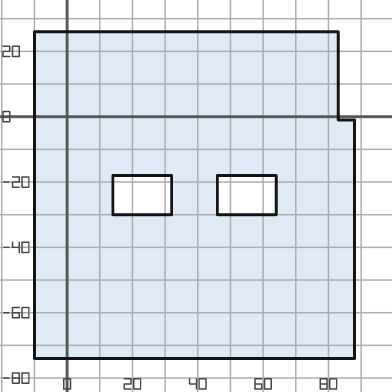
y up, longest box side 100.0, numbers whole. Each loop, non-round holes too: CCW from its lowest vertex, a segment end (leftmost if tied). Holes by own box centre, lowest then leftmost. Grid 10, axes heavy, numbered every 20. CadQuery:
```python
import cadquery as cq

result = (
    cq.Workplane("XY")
    .moveTo(-10.0, -74.0)
    .lineTo(88.0, -74.0)
    .lineTo(88.0, -1.0)
    .lineTo(83.0, -1.0)
    .lineTo(83.0, 26.0)
    .lineTo(-10.0, 26.0)
    .close()
    .moveTo(14.0, -30.0)
    .lineTo(32.0, -30.0)
    .lineTo(32.0, -18.0)
    .lineTo(14.0, -18.0)
    .close()
    .moveTo(46.0, -30.0)
    .lineTo(64.0, -30.0)
    .lineTo(64.0, -18.0)
    .lineTo(46.0, -18.0)
    .close()
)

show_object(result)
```